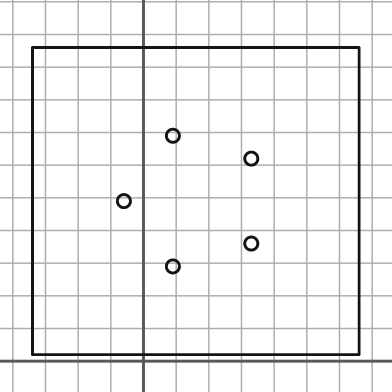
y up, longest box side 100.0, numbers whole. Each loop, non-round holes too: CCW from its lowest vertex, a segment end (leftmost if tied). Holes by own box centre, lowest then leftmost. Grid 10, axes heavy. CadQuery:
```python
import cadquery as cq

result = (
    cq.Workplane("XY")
    .moveTo(-34.0, 2.0)
    .lineTo(66.0, 2.0)
    .lineTo(66.0, 96.0)
    .lineTo(-34.0, 96.0)
    .close()
    .moveTo(9.0, 29.0)
    .circle(2.0)
    .moveTo(33.0, 36.0)
    .circle(2.0)
    .moveTo(-6.0, 49.0)
    .circle(2.0)
    .moveTo(33.0, 62.0)
    .circle(2.0)
    .moveTo(9.0, 69.0)
    .circle(2.0)
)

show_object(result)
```